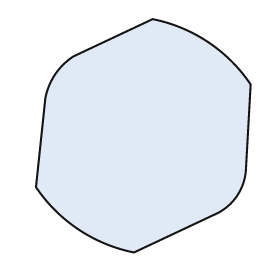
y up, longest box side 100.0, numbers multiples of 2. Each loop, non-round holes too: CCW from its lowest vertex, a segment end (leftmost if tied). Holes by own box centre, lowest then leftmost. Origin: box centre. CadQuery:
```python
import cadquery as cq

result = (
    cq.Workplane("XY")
    .moveTo(-4.0, -50.0)
    .lineTo(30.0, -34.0)
    .threePointArc((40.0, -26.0), (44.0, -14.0))
    .lineTo(46.0, 22.0)
    .threePointArc((28.0, 40.0), (4.0, 50.0))
    .lineTo(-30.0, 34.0)
    .threePointArc((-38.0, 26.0), (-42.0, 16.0))
    .lineTo(-46.0, -22.0)
    .threePointArc((-28.0, -40.0), (-4.0, -50.0))
    .close()
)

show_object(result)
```